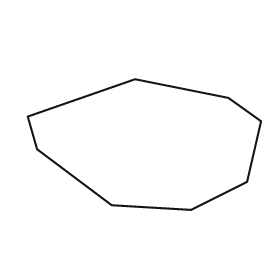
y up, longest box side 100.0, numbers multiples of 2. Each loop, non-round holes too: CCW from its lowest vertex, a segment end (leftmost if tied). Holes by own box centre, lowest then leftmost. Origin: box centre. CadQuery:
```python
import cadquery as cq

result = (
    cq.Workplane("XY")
    .moveTo(20.0, -28.0)
    .lineTo(44.0, -16.0)
    .lineTo(50.0, 10.0)
    .lineTo(36.0, 20.0)
    .lineTo(-4.0, 28.0)
    .lineTo(-50.0, 12.0)
    .lineTo(-46.0, -2.0)
    .lineTo(-14.0, -26.0)
    .close()
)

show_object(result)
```